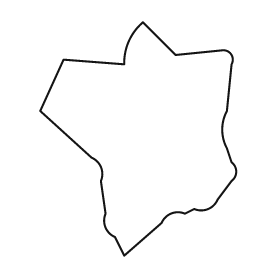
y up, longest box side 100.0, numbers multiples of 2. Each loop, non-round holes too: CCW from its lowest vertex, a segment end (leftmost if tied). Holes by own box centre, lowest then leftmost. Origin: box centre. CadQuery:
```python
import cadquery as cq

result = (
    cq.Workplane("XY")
    .moveTo(-6.0, -50.0)
    .lineTo(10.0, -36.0)
    .threePointArc((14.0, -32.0), (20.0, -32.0))
    .lineTo(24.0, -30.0)
    .threePointArc((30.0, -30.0), (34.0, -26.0))
    .lineTo(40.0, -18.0)
    .threePointArc((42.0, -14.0), (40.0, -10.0))
    .lineTo(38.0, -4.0)
    .threePointArc((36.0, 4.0), (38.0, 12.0))
    .lineTo(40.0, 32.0)
    .threePointArc((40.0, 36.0), (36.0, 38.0))
    .lineTo(16.0, 36.0)
    .lineTo(2.0, 50.0)
    .threePointArc((-4.0, 42.0), (-6.0, 32.0))
    .lineTo(-32.0, 34.0)
    .lineTo(-42.0, 12.0)
    .lineTo(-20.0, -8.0)
    .threePointArc((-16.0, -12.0), (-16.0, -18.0))
    .lineTo(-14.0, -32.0)
    .threePointArc((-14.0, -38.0), (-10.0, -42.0))
    .close()
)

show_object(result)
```